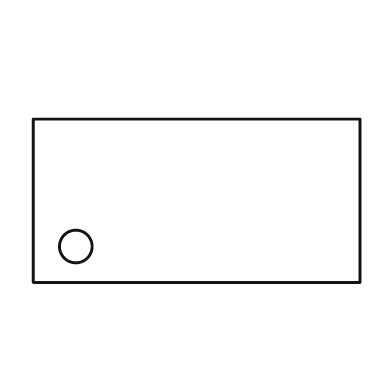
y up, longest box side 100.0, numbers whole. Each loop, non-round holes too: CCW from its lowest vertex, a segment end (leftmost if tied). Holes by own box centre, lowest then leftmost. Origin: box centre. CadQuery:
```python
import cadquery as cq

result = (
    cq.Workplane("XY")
    .moveTo(-50.0, -25.0)
    .lineTo(50.0, -25.0)
    .lineTo(50.0, 25.0)
    .lineTo(-50.0, 25.0)
    .close()
    .moveTo(-37.0, -14.0)
    .circle(5.0)
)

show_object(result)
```